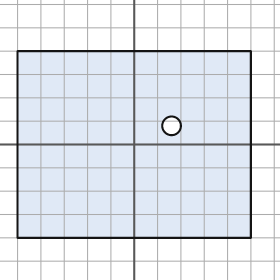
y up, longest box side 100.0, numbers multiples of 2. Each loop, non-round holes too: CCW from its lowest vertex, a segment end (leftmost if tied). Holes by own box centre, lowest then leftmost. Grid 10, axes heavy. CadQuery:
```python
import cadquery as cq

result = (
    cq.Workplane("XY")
    .moveTo(-50.0, -40.0)
    .lineTo(50.0, -40.0)
    .lineTo(50.0, 40.0)
    .lineTo(-50.0, 40.0)
    .close()
    .moveTo(16.0, 8.0)
    .circle(4.0)
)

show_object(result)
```